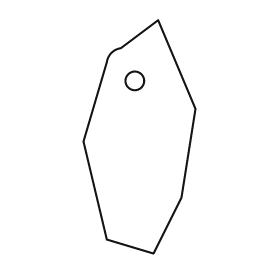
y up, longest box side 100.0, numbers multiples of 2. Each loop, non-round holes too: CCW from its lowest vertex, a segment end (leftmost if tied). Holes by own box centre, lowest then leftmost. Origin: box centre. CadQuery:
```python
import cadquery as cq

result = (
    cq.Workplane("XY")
    .moveTo(6.0, -50.0)
    .lineTo(18.0, -26.0)
    .lineTo(24.0, 12.0)
    .lineTo(8.0, 50.0)
    .lineTo(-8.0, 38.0)
    .threePointArc((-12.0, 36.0), (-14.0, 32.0))
    .lineTo(-24.0, -2.0)
    .lineTo(-14.0, -44.0)
    .close()
    .moveTo(-2.0, 24.0)
    .circle(4.0)
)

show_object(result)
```